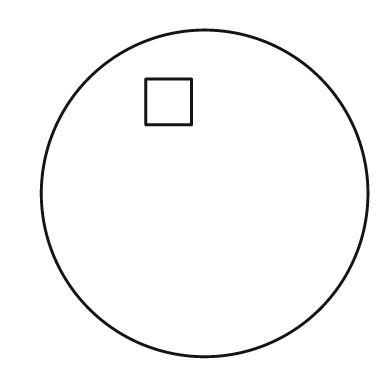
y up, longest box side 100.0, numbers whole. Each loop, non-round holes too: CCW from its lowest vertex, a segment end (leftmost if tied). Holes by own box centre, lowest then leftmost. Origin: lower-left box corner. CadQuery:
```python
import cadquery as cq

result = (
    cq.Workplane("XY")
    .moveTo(50.0, 50.0)
    .circle(50.0)
    .moveTo(32.0, 71.0)
    .lineTo(46.0, 71.0)
    .lineTo(46.0, 85.0)
    .lineTo(32.0, 85.0)
    .close()
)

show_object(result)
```